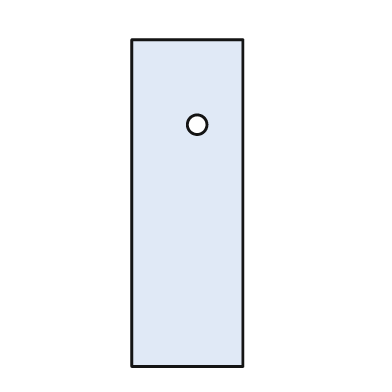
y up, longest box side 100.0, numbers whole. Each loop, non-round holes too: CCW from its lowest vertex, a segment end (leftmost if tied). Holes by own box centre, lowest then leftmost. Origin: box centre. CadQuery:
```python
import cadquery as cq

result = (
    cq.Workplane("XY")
    .moveTo(-17.0, -50.0)
    .lineTo(17.0, -50.0)
    .lineTo(17.0, 50.0)
    .lineTo(-17.0, 50.0)
    .close()
    .moveTo(3.0, 24.0)
    .circle(3.0)
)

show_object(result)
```